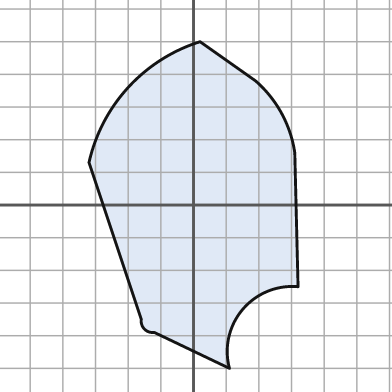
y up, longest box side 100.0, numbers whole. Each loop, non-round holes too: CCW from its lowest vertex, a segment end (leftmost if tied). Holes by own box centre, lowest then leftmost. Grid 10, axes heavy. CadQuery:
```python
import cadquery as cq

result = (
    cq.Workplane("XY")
    .moveTo(11.0, -50.0)
    .threePointArc((15.0, -32.0), (32.0, -25.0))
    .lineTo(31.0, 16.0)
    .threePointArc((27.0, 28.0), (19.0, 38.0))
    .lineTo(2.0, 50.0)
    .threePointArc((-20.0, 36.0), (-32.0, 13.0))
    .lineTo(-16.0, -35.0)
    .threePointArc((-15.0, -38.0), (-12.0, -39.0))
    .close()
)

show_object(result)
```